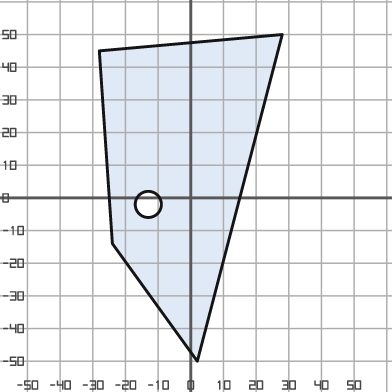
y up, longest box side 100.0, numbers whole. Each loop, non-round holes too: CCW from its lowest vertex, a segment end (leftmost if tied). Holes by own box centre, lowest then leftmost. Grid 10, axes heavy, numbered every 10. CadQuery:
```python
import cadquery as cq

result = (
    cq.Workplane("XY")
    .moveTo(2.0, -50.0)
    .lineTo(28.0, 50.0)
    .lineTo(-28.0, 45.0)
    .lineTo(-24.0, -14.0)
    .close()
    .moveTo(-13.0, -2.0)
    .circle(4.0)
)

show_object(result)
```